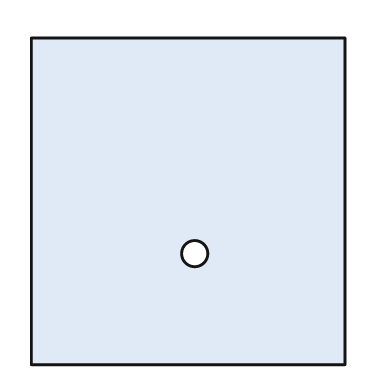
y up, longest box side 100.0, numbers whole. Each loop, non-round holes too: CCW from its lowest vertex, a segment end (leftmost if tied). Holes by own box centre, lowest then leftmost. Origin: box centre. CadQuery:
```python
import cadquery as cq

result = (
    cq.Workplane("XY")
    .moveTo(-48.0, -50.0)
    .lineTo(48.0, -50.0)
    .lineTo(48.0, 50.0)
    .lineTo(-48.0, 50.0)
    .close()
    .moveTo(2.0, -16.0)
    .circle(4.0)
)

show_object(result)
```